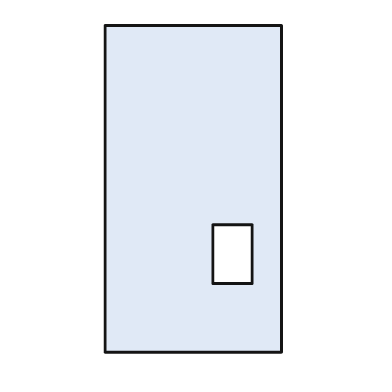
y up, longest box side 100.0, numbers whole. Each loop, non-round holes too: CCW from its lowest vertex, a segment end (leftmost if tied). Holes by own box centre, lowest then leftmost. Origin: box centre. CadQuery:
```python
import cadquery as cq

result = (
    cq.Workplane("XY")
    .moveTo(-27.0, -50.0)
    .lineTo(27.0, -50.0)
    .lineTo(27.0, 50.0)
    .lineTo(-27.0, 50.0)
    .close()
    .moveTo(6.0, -29.0)
    .lineTo(18.0, -29.0)
    .lineTo(18.0, -11.0)
    .lineTo(6.0, -11.0)
    .close()
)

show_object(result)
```